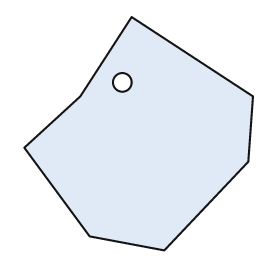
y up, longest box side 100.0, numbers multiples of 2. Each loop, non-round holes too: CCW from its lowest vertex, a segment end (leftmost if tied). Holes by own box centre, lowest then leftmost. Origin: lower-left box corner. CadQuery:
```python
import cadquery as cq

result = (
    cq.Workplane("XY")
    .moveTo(60.0, 0.0)
    .lineTo(96.0, 38.0)
    .lineTo(98.0, 66.0)
    .lineTo(46.0, 100.0)
    .lineTo(24.0, 66.0)
    .lineTo(0.0, 44.0)
    .lineTo(28.0, 6.0)
    .close()
    .moveTo(42.0, 72.0)
    .circle(4.0)
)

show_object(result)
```